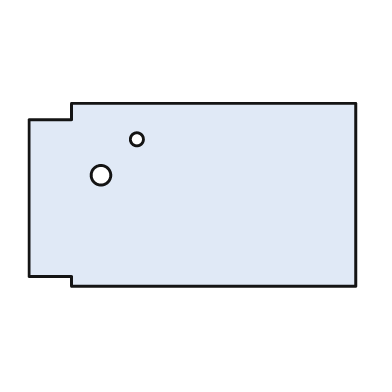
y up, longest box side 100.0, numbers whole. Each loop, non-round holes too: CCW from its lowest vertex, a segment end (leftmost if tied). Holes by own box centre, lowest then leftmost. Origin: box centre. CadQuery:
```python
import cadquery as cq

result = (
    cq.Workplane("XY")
    .moveTo(-37.0, -28.0)
    .lineTo(50.0, -28.0)
    .lineTo(50.0, 28.0)
    .lineTo(-37.0, 28.0)
    .lineTo(-37.0, 23.0)
    .lineTo(-50.0, 23.0)
    .lineTo(-50.0, -25.0)
    .lineTo(-37.0, -25.0)
    .close()
    .moveTo(-28.0, 6.0)
    .circle(3.0)
    .moveTo(-17.0, 17.0)
    .circle(2.0)
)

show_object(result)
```